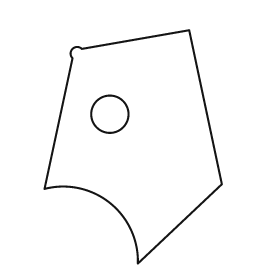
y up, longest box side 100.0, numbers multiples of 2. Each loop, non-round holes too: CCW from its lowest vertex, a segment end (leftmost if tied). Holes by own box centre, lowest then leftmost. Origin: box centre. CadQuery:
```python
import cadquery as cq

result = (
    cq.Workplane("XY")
    .moveTo(2.0, -50.0)
    .lineTo(38.0, -16.0)
    .lineTo(24.0, 50.0)
    .lineTo(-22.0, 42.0)
    .threePointArc((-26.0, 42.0), (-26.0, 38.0))
    .lineTo(-38.0, -18.0)
    .threePointArc((-10.0, -24.0), (2.0, -50.0))
    .close()
    .moveTo(-10.0, 14.0)
    .circle(8.0)
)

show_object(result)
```